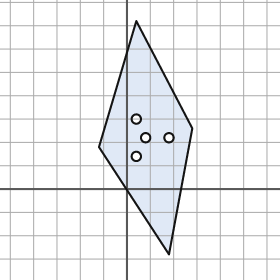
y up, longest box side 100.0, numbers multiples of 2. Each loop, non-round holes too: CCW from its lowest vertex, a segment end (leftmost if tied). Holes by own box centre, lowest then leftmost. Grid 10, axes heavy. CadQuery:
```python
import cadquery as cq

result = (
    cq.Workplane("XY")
    .moveTo(18.0, -28.0)
    .lineTo(28.0, 26.0)
    .lineTo(4.0, 72.0)
    .lineTo(-12.0, 18.0)
    .close()
    .moveTo(4.0, 14.0)
    .circle(2.0)
    .moveTo(8.0, 22.0)
    .circle(2.0)
    .moveTo(18.0, 22.0)
    .circle(2.0)
    .moveTo(4.0, 30.0)
    .circle(2.0)
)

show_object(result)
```